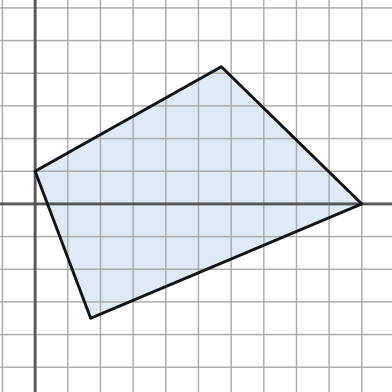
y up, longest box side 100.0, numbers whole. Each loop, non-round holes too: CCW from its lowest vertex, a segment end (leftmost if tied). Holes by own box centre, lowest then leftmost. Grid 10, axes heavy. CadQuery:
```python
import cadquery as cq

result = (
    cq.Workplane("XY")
    .moveTo(17.0, -35.0)
    .lineTo(100.0, 0.0)
    .lineTo(57.0, 42.0)
    .lineTo(0.0, 10.0)
    .close()
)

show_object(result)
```